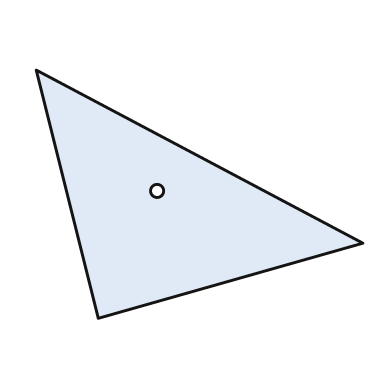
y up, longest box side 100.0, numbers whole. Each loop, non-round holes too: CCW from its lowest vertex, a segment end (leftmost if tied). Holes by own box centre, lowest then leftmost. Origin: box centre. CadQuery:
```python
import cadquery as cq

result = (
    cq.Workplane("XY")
    .moveTo(-31.0, -38.0)
    .lineTo(50.0, -15.0)
    .lineTo(-50.0, 38.0)
    .close()
    .moveTo(-13.0, 1.0)
    .circle(2.0)
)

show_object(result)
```